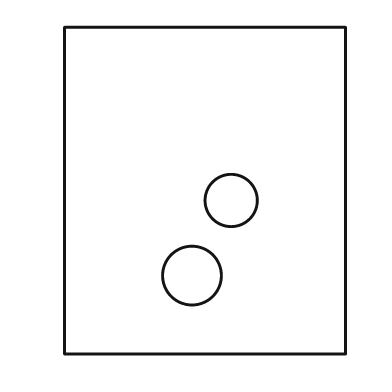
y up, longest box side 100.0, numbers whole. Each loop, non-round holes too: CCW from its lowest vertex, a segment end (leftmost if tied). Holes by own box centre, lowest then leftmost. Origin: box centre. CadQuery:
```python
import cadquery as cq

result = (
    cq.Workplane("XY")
    .moveTo(-43.0, -50.0)
    .lineTo(43.0, -50.0)
    .lineTo(43.0, 50.0)
    .lineTo(-43.0, 50.0)
    .close()
    .moveTo(-4.0, -26.0)
    .circle(9.0)
    .moveTo(8.0, -3.0)
    .circle(8.0)
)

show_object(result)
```